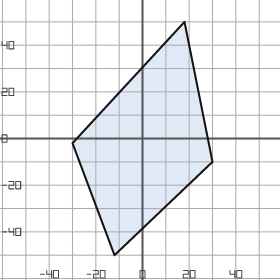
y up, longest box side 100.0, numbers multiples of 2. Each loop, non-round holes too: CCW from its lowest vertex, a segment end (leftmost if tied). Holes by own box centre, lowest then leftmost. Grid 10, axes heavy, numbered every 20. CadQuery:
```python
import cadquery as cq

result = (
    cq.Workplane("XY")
    .moveTo(-12.0, -50.0)
    .lineTo(30.0, -10.0)
    .lineTo(18.0, 50.0)
    .lineTo(-30.0, -2.0)
    .close()
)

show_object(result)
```